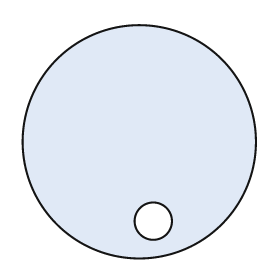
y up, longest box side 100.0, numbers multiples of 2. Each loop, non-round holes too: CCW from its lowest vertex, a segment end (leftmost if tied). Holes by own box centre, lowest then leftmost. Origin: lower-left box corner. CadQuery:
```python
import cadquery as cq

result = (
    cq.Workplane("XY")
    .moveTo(50.0, 50.0)
    .circle(50.0)
    .moveTo(56.0, 16.0)
    .circle(8.0)
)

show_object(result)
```